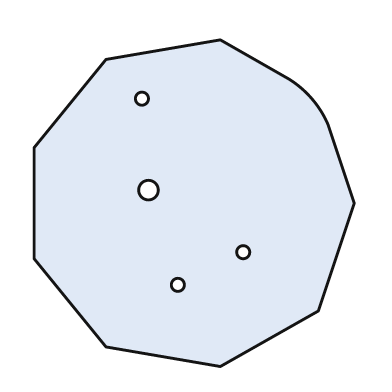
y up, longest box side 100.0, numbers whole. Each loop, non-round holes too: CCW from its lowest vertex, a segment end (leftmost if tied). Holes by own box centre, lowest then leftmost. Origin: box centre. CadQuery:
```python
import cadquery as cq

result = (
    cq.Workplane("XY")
    .moveTo(8.0, -50.0)
    .lineTo(38.0, -33.0)
    .lineTo(49.0, 0.0)
    .lineTo(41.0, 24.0)
    .threePointArc((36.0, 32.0), (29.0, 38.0))
    .lineTo(8.0, 50.0)
    .lineTo(-27.0, 44.0)
    .lineTo(-49.0, 17.0)
    .lineTo(-49.0, -17.0)
    .lineTo(-27.0, -44.0)
    .close()
    .moveTo(-5.0, -25.0)
    .circle(2.0)
    .moveTo(15.0, -15.0)
    .circle(2.0)
    .moveTo(-14.0, 4.0)
    .circle(3.0)
    .moveTo(-16.0, 32.0)
    .circle(2.0)
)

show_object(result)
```